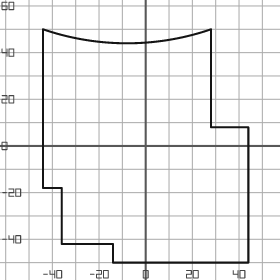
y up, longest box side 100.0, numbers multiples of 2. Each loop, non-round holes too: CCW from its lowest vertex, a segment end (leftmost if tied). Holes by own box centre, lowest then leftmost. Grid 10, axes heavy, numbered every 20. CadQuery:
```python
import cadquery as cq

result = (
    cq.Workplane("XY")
    .moveTo(-14.0, -50.0)
    .lineTo(44.0, -50.0)
    .lineTo(44.0, 8.0)
    .lineTo(28.0, 8.0)
    .lineTo(28.0, 50.0)
    .threePointArc((-8.0, 44.0), (-44.0, 50.0))
    .lineTo(-44.0, -18.0)
    .lineTo(-36.0, -18.0)
    .lineTo(-36.0, -42.0)
    .lineTo(-14.0, -42.0)
    .close()
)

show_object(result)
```